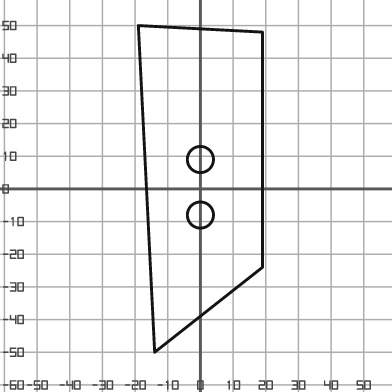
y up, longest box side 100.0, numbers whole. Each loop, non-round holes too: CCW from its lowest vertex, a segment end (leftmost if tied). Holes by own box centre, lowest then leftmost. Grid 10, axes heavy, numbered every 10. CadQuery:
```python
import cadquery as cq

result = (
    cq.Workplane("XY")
    .moveTo(-14.0, -50.0)
    .lineTo(19.0, -24.0)
    .lineTo(19.0, 48.0)
    .lineTo(-19.0, 50.0)
    .close()
    .moveTo(0.0, -8.0)
    .circle(4.0)
    .moveTo(0.0, 9.0)
    .circle(4.0)
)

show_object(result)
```